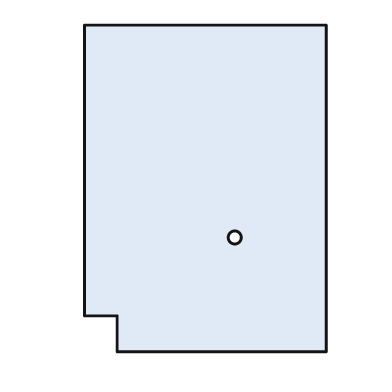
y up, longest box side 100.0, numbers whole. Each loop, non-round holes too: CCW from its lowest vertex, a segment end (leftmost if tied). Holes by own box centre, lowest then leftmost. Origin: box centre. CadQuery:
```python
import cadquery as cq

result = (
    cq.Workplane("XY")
    .moveTo(-27.0, -50.0)
    .lineTo(37.0, -50.0)
    .lineTo(37.0, 50.0)
    .lineTo(-37.0, 50.0)
    .lineTo(-37.0, -39.0)
    .lineTo(-27.0, -39.0)
    .close()
    .moveTo(9.0, -15.0)
    .circle(2.0)
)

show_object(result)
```